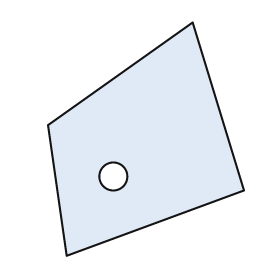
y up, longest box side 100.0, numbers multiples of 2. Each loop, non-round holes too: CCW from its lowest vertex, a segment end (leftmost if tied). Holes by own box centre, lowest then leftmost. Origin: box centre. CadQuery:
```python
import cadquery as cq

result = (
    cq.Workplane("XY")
    .moveTo(-34.0, -50.0)
    .lineTo(42.0, -22.0)
    .lineTo(20.0, 50.0)
    .lineTo(-42.0, 6.0)
    .close()
    .moveTo(-14.0, -16.0)
    .circle(6.0)
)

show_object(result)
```